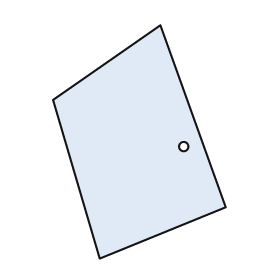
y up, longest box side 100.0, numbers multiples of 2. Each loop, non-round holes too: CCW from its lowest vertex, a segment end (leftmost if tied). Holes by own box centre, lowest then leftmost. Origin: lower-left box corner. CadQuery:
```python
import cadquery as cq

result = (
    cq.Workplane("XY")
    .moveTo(20.0, 0.0)
    .lineTo(74.0, 22.0)
    .lineTo(46.0, 100.0)
    .lineTo(0.0, 68.0)
    .close()
    .moveTo(56.0, 48.0)
    .circle(2.0)
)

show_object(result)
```